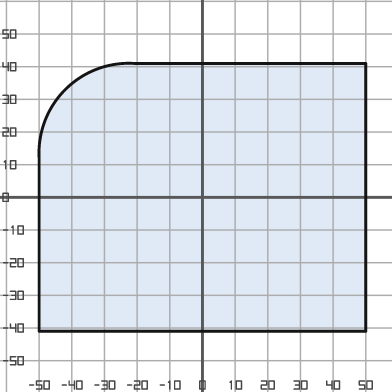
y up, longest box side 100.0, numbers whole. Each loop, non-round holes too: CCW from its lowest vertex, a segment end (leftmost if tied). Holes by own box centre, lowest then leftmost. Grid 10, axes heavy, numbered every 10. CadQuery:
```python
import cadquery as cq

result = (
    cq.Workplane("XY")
    .moveTo(-50.0, -41.0)
    .lineTo(50.0, -41.0)
    .lineTo(50.0, 41.0)
    .lineTo(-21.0, 41.0)
    .threePointArc((-42.0, 33.0), (-50.0, 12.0))
    .close()
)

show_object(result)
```